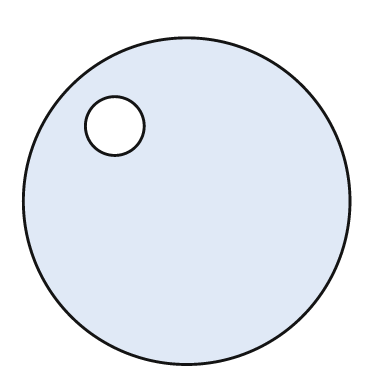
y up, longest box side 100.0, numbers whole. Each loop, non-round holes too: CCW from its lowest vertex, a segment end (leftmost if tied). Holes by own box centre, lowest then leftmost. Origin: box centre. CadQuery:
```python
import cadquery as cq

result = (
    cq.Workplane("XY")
    .moveTo(0.0, 0.0)
    .circle(50.0)
    .moveTo(-22.0, 23.0)
    .circle(9.0)
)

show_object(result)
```